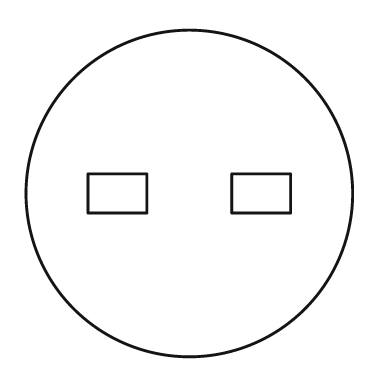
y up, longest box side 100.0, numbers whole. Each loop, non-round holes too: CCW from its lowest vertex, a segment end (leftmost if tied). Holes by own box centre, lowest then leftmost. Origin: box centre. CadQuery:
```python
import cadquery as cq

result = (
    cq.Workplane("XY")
    .moveTo(0.0, 0.0)
    .circle(50.0)
    .moveTo(-31.0, -6.0)
    .lineTo(-13.0, -6.0)
    .lineTo(-13.0, 6.0)
    .lineTo(-31.0, 6.0)
    .close()
    .moveTo(13.0, -6.0)
    .lineTo(31.0, -6.0)
    .lineTo(31.0, 6.0)
    .lineTo(13.0, 6.0)
    .close()
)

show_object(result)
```